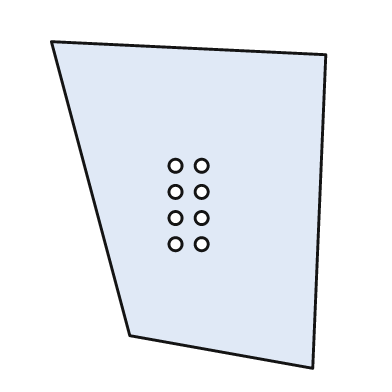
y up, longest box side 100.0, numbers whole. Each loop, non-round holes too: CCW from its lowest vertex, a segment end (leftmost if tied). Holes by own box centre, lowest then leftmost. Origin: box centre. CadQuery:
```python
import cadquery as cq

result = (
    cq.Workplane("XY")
    .moveTo(38.0, -50.0)
    .lineTo(42.0, 46.0)
    .lineTo(-42.0, 50.0)
    .lineTo(-18.0, -40.0)
    .close()
    .moveTo(-4.0, -12.0)
    .circle(2.0)
    .moveTo(4.0, -12.0)
    .circle(2.0)
    .moveTo(-4.0, -4.0)
    .circle(2.0)
    .moveTo(4.0, -4.0)
    .circle(2.0)
    .moveTo(-4.0, 4.0)
    .circle(2.0)
    .moveTo(4.0, 4.0)
    .circle(2.0)
    .moveTo(-4.0, 12.0)
    .circle(2.0)
    .moveTo(4.0, 12.0)
    .circle(2.0)
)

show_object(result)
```